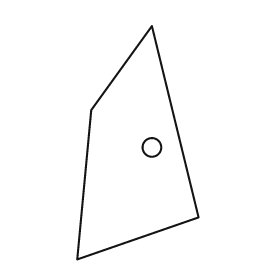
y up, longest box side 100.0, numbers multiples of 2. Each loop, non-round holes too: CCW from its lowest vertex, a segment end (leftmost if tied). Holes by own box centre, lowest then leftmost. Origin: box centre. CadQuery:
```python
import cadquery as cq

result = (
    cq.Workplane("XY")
    .moveTo(-26.0, -50.0)
    .lineTo(26.0, -32.0)
    .lineTo(6.0, 50.0)
    .lineTo(-20.0, 14.0)
    .close()
    .moveTo(6.0, -2.0)
    .circle(4.0)
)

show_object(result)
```